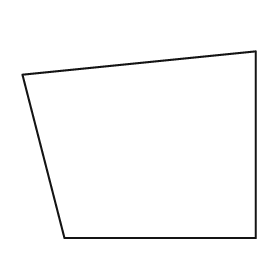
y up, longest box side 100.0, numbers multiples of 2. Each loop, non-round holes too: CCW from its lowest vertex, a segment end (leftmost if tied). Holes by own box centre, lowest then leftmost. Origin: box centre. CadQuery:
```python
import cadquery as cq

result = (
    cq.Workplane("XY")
    .moveTo(-32.0, -40.0)
    .lineTo(50.0, -40.0)
    .lineTo(50.0, 40.0)
    .lineTo(-50.0, 30.0)
    .close()
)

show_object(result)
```